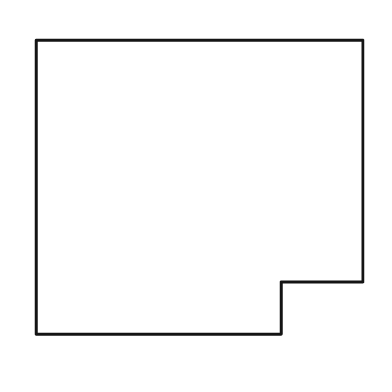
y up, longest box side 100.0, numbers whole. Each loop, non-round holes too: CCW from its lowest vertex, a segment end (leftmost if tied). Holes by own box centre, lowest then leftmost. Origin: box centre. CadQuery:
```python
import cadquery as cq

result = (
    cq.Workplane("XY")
    .moveTo(-50.0, -45.0)
    .lineTo(25.0, -45.0)
    .lineTo(25.0, -29.0)
    .lineTo(50.0, -29.0)
    .lineTo(50.0, 45.0)
    .lineTo(-50.0, 45.0)
    .close()
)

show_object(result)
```